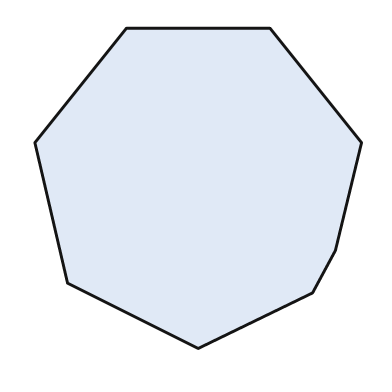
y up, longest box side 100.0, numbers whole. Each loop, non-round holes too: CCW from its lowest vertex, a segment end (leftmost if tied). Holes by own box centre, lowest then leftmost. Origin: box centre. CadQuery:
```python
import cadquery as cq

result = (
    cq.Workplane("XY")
    .moveTo(0.0, -49.0)
    .lineTo(35.0, -32.0)
    .lineTo(42.0, -19.0)
    .lineTo(50.0, 14.0)
    .lineTo(22.0, 49.0)
    .lineTo(-22.0, 49.0)
    .lineTo(-50.0, 14.0)
    .lineTo(-40.0, -29.0)
    .close()
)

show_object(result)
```